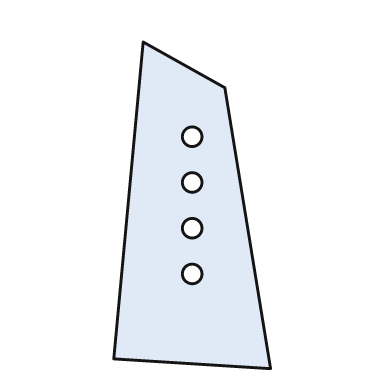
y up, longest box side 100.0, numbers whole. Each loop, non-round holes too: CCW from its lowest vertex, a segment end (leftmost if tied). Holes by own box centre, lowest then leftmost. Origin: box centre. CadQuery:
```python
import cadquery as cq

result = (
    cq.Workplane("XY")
    .moveTo(24.0, -50.0)
    .lineTo(10.0, 36.0)
    .lineTo(-15.0, 50.0)
    .lineTo(-24.0, -47.0)
    .close()
    .moveTo(0.0, -21.0)
    .circle(3.0)
    .moveTo(0.0, -7.0)
    .circle(3.0)
    .moveTo(0.0, 7.0)
    .circle(3.0)
    .moveTo(0.0, 21.0)
    .circle(3.0)
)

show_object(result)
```